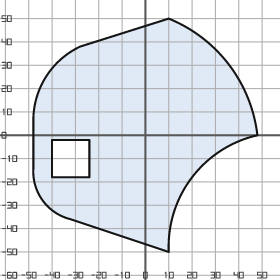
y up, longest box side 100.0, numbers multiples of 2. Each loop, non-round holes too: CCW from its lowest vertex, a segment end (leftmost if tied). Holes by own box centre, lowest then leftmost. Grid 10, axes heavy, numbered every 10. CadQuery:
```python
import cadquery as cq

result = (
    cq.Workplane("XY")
    .moveTo(10.0, -50.0)
    .threePointArc((20.0, -18.0), (48.0, 0.0))
    .threePointArc((36.0, 30.0), (10.0, 50.0))
    .lineTo(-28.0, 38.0)
    .threePointArc((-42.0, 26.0), (-48.0, 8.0))
    .lineTo(-48.0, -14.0)
    .threePointArc((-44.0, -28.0), (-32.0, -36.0))
    .close()
    .moveTo(-40.0, -18.0)
    .lineTo(-24.0, -18.0)
    .lineTo(-24.0, -2.0)
    .lineTo(-40.0, -2.0)
    .close()
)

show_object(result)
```